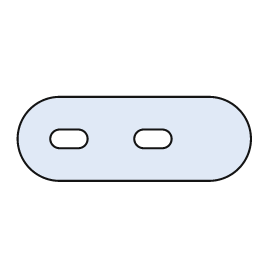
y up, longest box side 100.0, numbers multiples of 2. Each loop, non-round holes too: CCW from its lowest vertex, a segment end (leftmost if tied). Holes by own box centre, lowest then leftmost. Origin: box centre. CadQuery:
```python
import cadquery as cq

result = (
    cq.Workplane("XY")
    .moveTo(-32.0, -18.0)
    .lineTo(32.0, -18.0)
    .threePointArc((50.0, 0.0), (32.0, 18.0))
    .lineTo(-32.0, 18.0)
    .threePointArc((-50.0, 0.0), (-32.0, -18.0))
    .close()
    .moveTo(-32.0, -4.0)
    .lineTo(-24.0, -4.0)
    .threePointArc((-20.0, 0.0), (-24.0, 4.0))
    .lineTo(-32.0, 4.0)
    .threePointArc((-36.0, 0.0), (-32.0, -4.0))
    .close()
    .moveTo(4.0, -4.0)
    .lineTo(12.0, -4.0)
    .threePointArc((16.0, 0.0), (12.0, 4.0))
    .lineTo(4.0, 4.0)
    .threePointArc((0.0, 0.0), (4.0, -4.0))
    .close()
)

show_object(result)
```